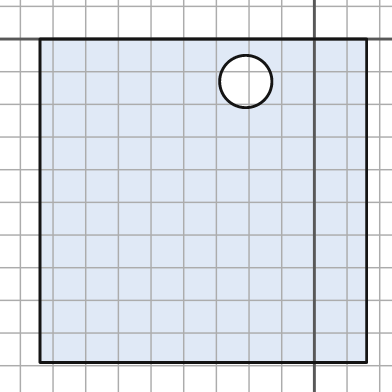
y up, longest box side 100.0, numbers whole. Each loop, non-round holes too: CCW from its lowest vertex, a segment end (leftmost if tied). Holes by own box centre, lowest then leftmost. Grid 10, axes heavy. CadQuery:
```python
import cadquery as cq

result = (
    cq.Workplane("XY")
    .moveTo(-84.0, -99.0)
    .lineTo(16.0, -99.0)
    .lineTo(16.0, 0.0)
    .lineTo(-84.0, 0.0)
    .close()
    .moveTo(-21.0, -13.0)
    .circle(8.0)
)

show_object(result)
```